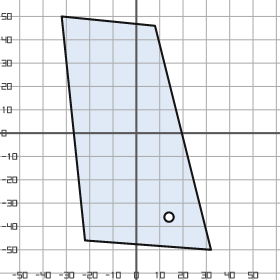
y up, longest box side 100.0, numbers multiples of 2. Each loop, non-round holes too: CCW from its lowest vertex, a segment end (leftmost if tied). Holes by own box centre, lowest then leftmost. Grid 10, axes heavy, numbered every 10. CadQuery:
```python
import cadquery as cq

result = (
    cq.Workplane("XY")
    .moveTo(32.0, -50.0)
    .lineTo(8.0, 46.0)
    .lineTo(-32.0, 50.0)
    .lineTo(-22.0, -46.0)
    .close()
    .moveTo(14.0, -36.0)
    .circle(2.0)
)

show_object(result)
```